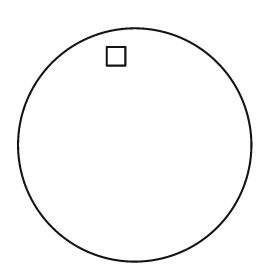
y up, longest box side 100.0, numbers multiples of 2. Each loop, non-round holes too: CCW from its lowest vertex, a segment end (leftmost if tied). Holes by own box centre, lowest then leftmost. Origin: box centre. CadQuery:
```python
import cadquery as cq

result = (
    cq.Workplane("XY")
    .moveTo(0.0, 0.0)
    .circle(50.0)
    .moveTo(-12.0, 34.0)
    .lineTo(-4.0, 34.0)
    .lineTo(-4.0, 42.0)
    .lineTo(-12.0, 42.0)
    .close()
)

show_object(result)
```